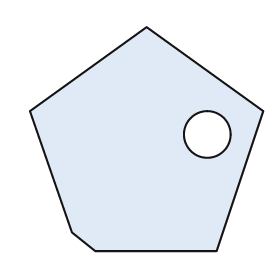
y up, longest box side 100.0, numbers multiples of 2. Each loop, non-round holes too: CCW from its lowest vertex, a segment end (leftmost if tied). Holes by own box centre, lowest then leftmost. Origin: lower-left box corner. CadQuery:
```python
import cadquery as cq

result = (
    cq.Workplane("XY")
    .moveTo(28.0, 0.0)
    .lineTo(80.0, 0.0)
    .lineTo(100.0, 60.0)
    .lineTo(50.0, 96.0)
    .lineTo(0.0, 60.0)
    .lineTo(18.0, 8.0)
    .close()
    .moveTo(76.0, 50.0)
    .circle(10.0)
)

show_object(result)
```